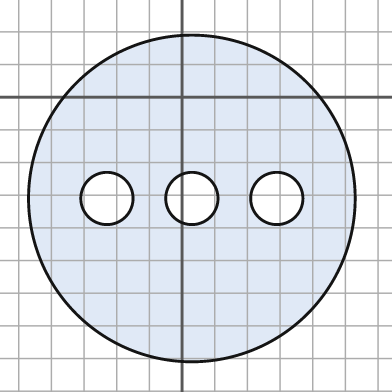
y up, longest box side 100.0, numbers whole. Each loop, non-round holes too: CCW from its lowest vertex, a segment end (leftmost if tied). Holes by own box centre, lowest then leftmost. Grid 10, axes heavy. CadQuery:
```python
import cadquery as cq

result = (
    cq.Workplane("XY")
    .moveTo(3.0, -31.0)
    .circle(50.0)
    .moveTo(-23.0, -31.0)
    .circle(8.0)
    .moveTo(3.0, -31.0)
    .circle(8.0)
    .moveTo(29.0, -31.0)
    .circle(8.0)
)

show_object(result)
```